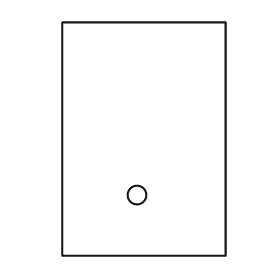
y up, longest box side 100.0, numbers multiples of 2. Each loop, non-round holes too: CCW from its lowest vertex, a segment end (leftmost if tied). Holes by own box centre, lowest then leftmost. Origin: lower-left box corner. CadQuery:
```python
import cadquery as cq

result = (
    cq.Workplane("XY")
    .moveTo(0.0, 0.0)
    .lineTo(70.0, 0.0)
    .lineTo(70.0, 100.0)
    .lineTo(0.0, 100.0)
    .close()
    .moveTo(32.0, 26.0)
    .circle(4.0)
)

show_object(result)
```